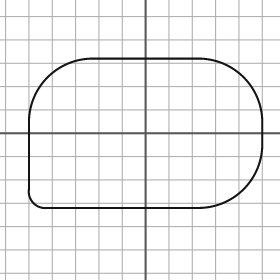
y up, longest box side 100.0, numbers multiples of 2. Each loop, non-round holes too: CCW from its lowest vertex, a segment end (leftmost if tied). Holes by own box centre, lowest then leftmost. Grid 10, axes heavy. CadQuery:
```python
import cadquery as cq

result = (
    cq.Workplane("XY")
    .moveTo(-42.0, -32.0)
    .lineTo(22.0, -32.0)
    .threePointArc((42.0, -24.0), (50.0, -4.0))
    .lineTo(50.0, 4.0)
    .threePointArc((42.0, 24.0), (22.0, 32.0))
    .lineTo(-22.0, 32.0)
    .threePointArc((-42.0, 24.0), (-50.0, 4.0))
    .lineTo(-50.0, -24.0)
    .threePointArc((-48.0, -30.0), (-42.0, -32.0))
    .close()
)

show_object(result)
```